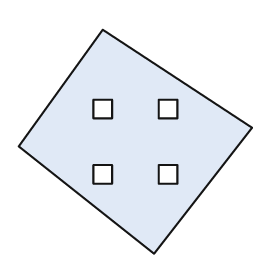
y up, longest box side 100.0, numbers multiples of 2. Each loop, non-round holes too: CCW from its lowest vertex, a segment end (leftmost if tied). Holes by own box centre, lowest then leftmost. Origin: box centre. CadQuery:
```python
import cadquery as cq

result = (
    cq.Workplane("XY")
    .moveTo(8.0, -48.0)
    .lineTo(50.0, 6.0)
    .lineTo(-14.0, 48.0)
    .lineTo(-50.0, -2.0)
    .close()
    .moveTo(-18.0, -18.0)
    .lineTo(-10.0, -18.0)
    .lineTo(-10.0, -10.0)
    .lineTo(-18.0, -10.0)
    .close()
    .moveTo(10.0, -18.0)
    .lineTo(18.0, -18.0)
    .lineTo(18.0, -10.0)
    .lineTo(10.0, -10.0)
    .close()
    .moveTo(-18.0, 10.0)
    .lineTo(-10.0, 10.0)
    .lineTo(-10.0, 18.0)
    .lineTo(-18.0, 18.0)
    .close()
    .moveTo(10.0, 10.0)
    .lineTo(18.0, 10.0)
    .lineTo(18.0, 18.0)
    .lineTo(10.0, 18.0)
    .close()
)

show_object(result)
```